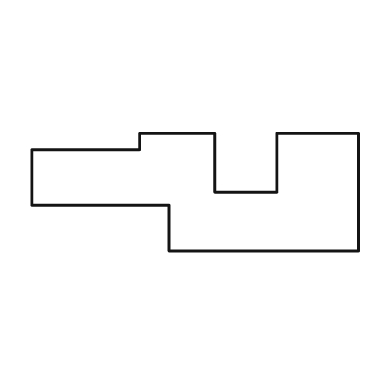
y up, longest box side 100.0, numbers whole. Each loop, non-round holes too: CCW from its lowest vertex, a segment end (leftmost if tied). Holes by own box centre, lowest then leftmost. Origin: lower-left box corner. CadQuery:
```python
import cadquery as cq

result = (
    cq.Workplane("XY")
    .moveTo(42.0, 0.0)
    .lineTo(100.0, 0.0)
    .lineTo(100.0, 36.0)
    .lineTo(75.0, 36.0)
    .lineTo(75.0, 18.0)
    .lineTo(56.0, 18.0)
    .lineTo(56.0, 36.0)
    .lineTo(33.0, 36.0)
    .lineTo(33.0, 31.0)
    .lineTo(0.0, 31.0)
    .lineTo(0.0, 14.0)
    .lineTo(42.0, 14.0)
    .close()
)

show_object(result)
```